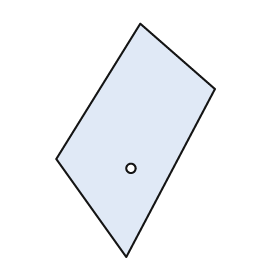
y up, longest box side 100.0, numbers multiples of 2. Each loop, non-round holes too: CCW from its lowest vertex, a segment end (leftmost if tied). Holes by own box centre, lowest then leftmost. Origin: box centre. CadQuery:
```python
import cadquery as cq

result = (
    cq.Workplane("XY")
    .moveTo(-4.0, -50.0)
    .lineTo(34.0, 22.0)
    .lineTo(2.0, 50.0)
    .lineTo(-34.0, -8.0)
    .close()
    .moveTo(-2.0, -12.0)
    .circle(2.0)
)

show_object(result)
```